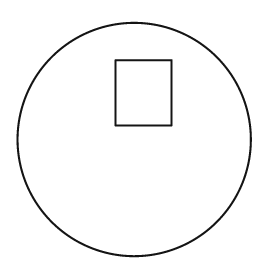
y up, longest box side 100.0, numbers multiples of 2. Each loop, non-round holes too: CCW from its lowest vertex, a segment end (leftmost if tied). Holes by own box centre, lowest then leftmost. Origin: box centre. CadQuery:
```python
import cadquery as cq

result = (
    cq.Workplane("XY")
    .moveTo(0.0, 0.0)
    .circle(50.0)
    .moveTo(-8.0, 6.0)
    .lineTo(16.0, 6.0)
    .lineTo(16.0, 34.0)
    .lineTo(-8.0, 34.0)
    .close()
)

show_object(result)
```